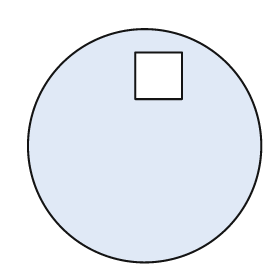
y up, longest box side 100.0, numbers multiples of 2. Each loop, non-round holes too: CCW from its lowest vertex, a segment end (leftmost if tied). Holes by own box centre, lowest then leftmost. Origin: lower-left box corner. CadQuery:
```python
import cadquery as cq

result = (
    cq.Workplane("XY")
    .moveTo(50.0, 50.0)
    .circle(50.0)
    .moveTo(46.0, 70.0)
    .lineTo(66.0, 70.0)
    .lineTo(66.0, 90.0)
    .lineTo(46.0, 90.0)
    .close()
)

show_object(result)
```